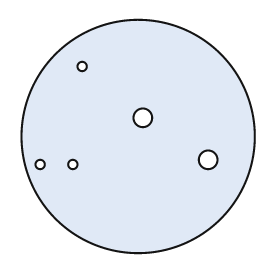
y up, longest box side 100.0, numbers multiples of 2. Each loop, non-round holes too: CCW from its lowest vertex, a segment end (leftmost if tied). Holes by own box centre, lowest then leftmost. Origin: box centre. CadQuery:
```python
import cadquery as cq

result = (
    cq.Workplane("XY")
    .moveTo(0.0, 0.0)
    .circle(50.0)
    .moveTo(-42.0, -12.0)
    .circle(2.0)
    .moveTo(-28.0, -12.0)
    .circle(2.0)
    .moveTo(30.0, -10.0)
    .circle(4.0)
    .moveTo(2.0, 8.0)
    .circle(4.0)
    .moveTo(-24.0, 30.0)
    .circle(2.0)
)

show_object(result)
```